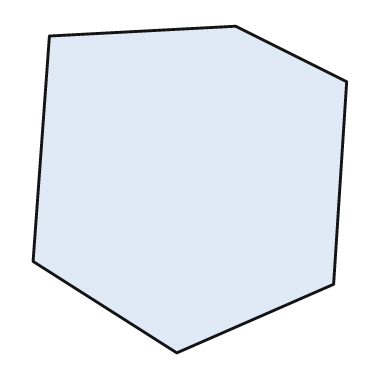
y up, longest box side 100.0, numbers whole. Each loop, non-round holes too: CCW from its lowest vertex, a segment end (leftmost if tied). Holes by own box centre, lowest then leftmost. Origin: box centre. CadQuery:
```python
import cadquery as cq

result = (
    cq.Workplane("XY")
    .moveTo(-4.0, -50.0)
    .lineTo(44.0, -29.0)
    .lineTo(48.0, 33.0)
    .lineTo(14.0, 50.0)
    .lineTo(-43.0, 47.0)
    .lineTo(-48.0, -22.0)
    .close()
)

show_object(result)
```